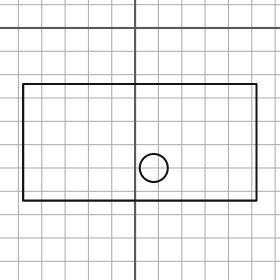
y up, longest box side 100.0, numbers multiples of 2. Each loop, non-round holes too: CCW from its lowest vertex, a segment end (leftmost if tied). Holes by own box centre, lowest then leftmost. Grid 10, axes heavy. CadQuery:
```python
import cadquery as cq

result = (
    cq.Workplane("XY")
    .moveTo(-48.0, -74.0)
    .lineTo(52.0, -74.0)
    .lineTo(52.0, -24.0)
    .lineTo(-48.0, -24.0)
    .close()
    .moveTo(8.0, -60.0)
    .circle(6.0)
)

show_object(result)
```